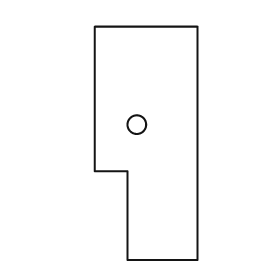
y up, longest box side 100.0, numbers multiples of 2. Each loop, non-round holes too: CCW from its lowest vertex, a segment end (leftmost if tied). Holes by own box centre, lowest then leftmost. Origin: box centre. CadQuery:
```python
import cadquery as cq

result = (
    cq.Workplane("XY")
    .moveTo(-8.0, -50.0)
    .lineTo(22.0, -50.0)
    .lineTo(22.0, 50.0)
    .lineTo(-22.0, 50.0)
    .lineTo(-22.0, -12.0)
    .lineTo(-8.0, -12.0)
    .close()
    .moveTo(-4.0, 8.0)
    .circle(4.0)
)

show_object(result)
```